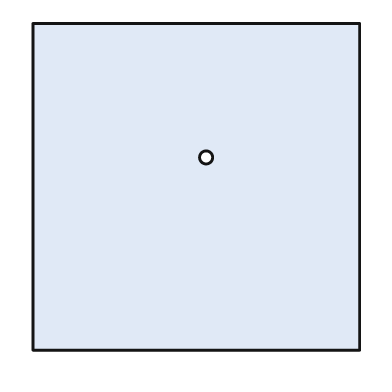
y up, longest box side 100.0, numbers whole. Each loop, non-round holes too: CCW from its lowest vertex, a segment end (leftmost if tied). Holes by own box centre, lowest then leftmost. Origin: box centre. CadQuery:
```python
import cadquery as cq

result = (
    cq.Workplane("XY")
    .moveTo(-50.0, -50.0)
    .lineTo(50.0, -50.0)
    .lineTo(50.0, 50.0)
    .lineTo(-50.0, 50.0)
    .close()
    .moveTo(3.0, 9.0)
    .circle(2.0)
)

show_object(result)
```